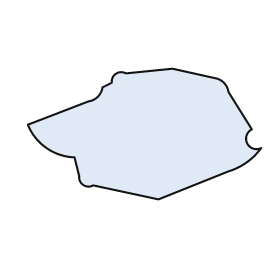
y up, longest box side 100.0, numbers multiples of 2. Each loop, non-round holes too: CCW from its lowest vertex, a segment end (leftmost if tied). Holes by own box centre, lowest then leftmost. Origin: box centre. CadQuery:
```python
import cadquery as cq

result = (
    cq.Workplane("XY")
    .moveTo(6.0, -28.0)
    .lineTo(36.0, -16.0)
    .threePointArc((44.0, -12.0), (50.0, -6.0))
    .threePointArc((44.0, -4.0), (46.0, 2.0))
    .lineTo(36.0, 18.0)
    .threePointArc((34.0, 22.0), (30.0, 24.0))
    .lineTo(12.0, 28.0)
    .lineTo(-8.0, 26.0)
    .threePointArc((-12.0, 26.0), (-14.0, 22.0))
    .lineTo(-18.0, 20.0)
    .threePointArc((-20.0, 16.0), (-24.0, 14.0))
    .lineTo(-50.0, 4.0)
    .threePointArc((-42.0, -6.0), (-30.0, -10.0))
    .lineTo(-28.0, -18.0)
    .threePointArc((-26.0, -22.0), (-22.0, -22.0))
    .close()
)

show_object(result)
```